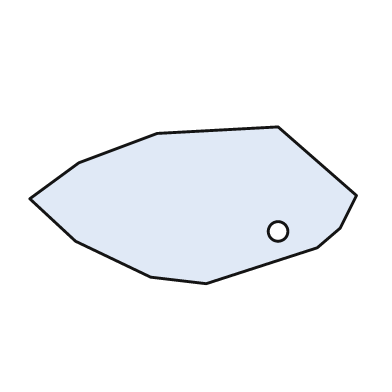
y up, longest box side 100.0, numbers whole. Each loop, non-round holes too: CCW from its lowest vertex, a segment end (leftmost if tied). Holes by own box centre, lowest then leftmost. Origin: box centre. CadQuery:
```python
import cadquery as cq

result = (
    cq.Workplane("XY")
    .moveTo(4.0, -24.0)
    .lineTo(38.0, -13.0)
    .lineTo(45.0, -7.0)
    .lineTo(50.0, 3.0)
    .lineTo(26.0, 24.0)
    .lineTo(-11.0, 22.0)
    .lineTo(-35.0, 13.0)
    .lineTo(-50.0, 2.0)
    .lineTo(-36.0, -11.0)
    .lineTo(-13.0, -22.0)
    .close()
    .moveTo(26.0, -8.0)
    .circle(3.0)
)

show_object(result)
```